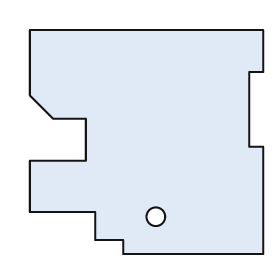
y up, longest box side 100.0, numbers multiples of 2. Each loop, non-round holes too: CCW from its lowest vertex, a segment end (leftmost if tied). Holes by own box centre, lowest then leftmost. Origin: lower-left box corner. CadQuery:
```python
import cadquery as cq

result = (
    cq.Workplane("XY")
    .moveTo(40.0, 0.0)
    .lineTo(100.0, 0.0)
    .lineTo(100.0, 46.0)
    .lineTo(94.0, 46.0)
    .lineTo(94.0, 78.0)
    .lineTo(100.0, 78.0)
    .lineTo(100.0, 96.0)
    .lineTo(0.0, 96.0)
    .lineTo(0.0, 68.0)
    .lineTo(10.0, 58.0)
    .lineTo(24.0, 58.0)
    .lineTo(24.0, 40.0)
    .lineTo(0.0, 40.0)
    .lineTo(0.0, 18.0)
    .lineTo(28.0, 18.0)
    .lineTo(28.0, 6.0)
    .lineTo(40.0, 6.0)
    .close()
    .moveTo(54.0, 16.0)
    .circle(4.0)
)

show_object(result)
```